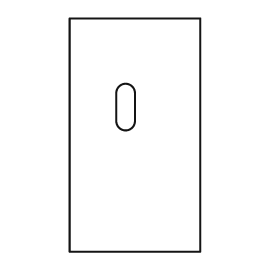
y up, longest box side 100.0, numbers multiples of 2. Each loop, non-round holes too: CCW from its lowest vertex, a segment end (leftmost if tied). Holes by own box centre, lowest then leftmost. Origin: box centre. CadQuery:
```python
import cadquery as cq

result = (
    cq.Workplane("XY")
    .moveTo(-28.0, -50.0)
    .lineTo(28.0, -50.0)
    .lineTo(28.0, 50.0)
    .lineTo(-28.0, 50.0)
    .close()
    .moveTo(-8.0, 6.0)
    .threePointArc((-4.0, 2.0), (0.0, 6.0))
    .lineTo(0.0, 18.0)
    .threePointArc((-4.0, 22.0), (-8.0, 18.0))
    .close()
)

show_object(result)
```